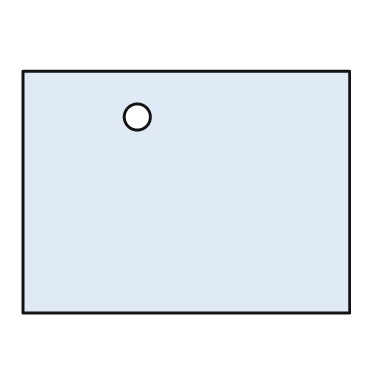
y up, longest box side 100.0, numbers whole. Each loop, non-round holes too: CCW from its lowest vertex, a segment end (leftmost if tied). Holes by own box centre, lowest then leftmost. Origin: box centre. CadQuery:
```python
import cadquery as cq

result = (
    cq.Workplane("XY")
    .moveTo(-50.0, -37.0)
    .lineTo(50.0, -37.0)
    .lineTo(50.0, 37.0)
    .lineTo(-50.0, 37.0)
    .close()
    .moveTo(-15.0, 23.0)
    .circle(4.0)
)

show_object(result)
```